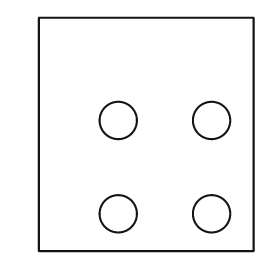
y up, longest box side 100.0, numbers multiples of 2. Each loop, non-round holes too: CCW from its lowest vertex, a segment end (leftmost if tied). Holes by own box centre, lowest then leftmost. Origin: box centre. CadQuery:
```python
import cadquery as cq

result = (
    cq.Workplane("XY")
    .moveTo(-46.0, -50.0)
    .lineTo(46.0, -50.0)
    .lineTo(46.0, 50.0)
    .lineTo(-46.0, 50.0)
    .close()
    .moveTo(-12.0, -34.0)
    .circle(8.0)
    .moveTo(28.0, -34.0)
    .circle(8.0)
    .moveTo(-12.0, 6.0)
    .circle(8.0)
    .moveTo(28.0, 6.0)
    .circle(8.0)
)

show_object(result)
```